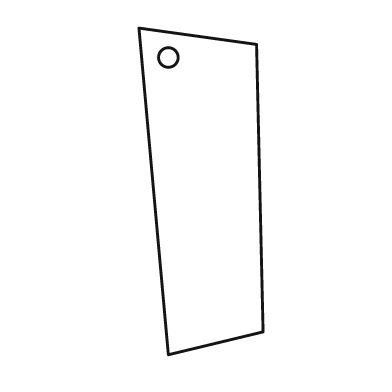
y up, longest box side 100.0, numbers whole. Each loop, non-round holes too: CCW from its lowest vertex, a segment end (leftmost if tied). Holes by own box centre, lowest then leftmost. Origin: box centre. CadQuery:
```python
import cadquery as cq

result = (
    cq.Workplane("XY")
    .moveTo(-10.0, -50.0)
    .lineTo(19.0, -43.0)
    .lineTo(17.0, 45.0)
    .lineTo(-19.0, 50.0)
    .close()
    .moveTo(-10.0, 41.0)
    .circle(3.0)
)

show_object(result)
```